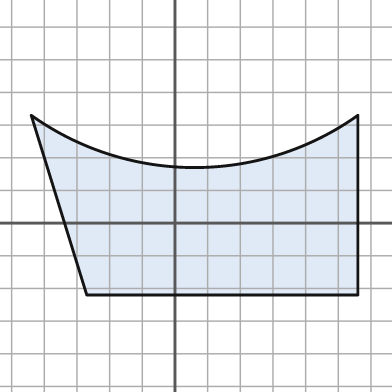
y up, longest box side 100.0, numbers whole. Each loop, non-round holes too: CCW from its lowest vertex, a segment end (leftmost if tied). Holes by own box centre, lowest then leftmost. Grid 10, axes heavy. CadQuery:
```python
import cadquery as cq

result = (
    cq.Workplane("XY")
    .moveTo(-27.0, -22.0)
    .lineTo(56.0, -22.0)
    .lineTo(56.0, 33.0)
    .threePointArc((6.0, 17.0), (-44.0, 33.0))
    .close()
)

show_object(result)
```